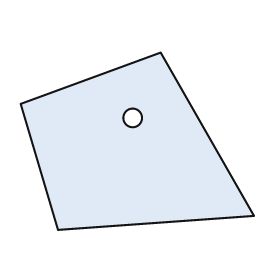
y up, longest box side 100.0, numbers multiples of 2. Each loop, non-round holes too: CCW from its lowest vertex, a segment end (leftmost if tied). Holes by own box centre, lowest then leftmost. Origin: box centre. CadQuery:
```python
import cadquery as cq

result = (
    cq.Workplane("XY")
    .moveTo(-34.0, -38.0)
    .lineTo(50.0, -32.0)
    .lineTo(10.0, 38.0)
    .lineTo(-50.0, 16.0)
    .close()
    .moveTo(-2.0, 10.0)
    .circle(4.0)
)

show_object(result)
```